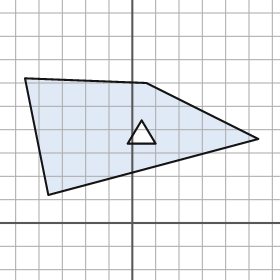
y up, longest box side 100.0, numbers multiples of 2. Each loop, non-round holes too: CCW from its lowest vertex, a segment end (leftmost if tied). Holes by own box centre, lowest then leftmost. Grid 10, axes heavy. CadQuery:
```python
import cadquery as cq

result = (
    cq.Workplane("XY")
    .moveTo(-36.0, 12.0)
    .lineTo(54.0, 36.0)
    .lineTo(6.0, 60.0)
    .lineTo(-46.0, 62.0)
    .close()
    .moveTo(-2.0, 34.0)
    .lineTo(10.0, 34.0)
    .lineTo(4.0, 44.0)
    .close()
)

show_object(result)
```